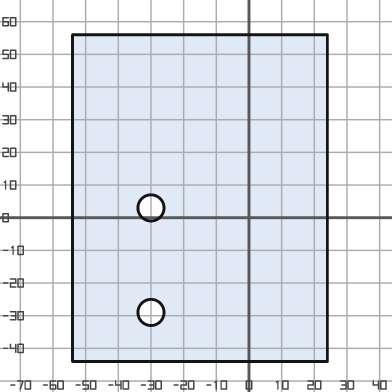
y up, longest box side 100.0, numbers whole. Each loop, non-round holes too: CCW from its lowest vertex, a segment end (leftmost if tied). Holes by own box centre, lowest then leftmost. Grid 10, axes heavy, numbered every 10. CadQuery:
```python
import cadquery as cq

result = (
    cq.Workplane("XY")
    .moveTo(-54.0, -44.0)
    .lineTo(24.0, -44.0)
    .lineTo(24.0, 56.0)
    .lineTo(-54.0, 56.0)
    .close()
    .moveTo(-30.0, -29.0)
    .circle(4.0)
    .moveTo(-30.0, 3.0)
    .circle(4.0)
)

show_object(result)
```